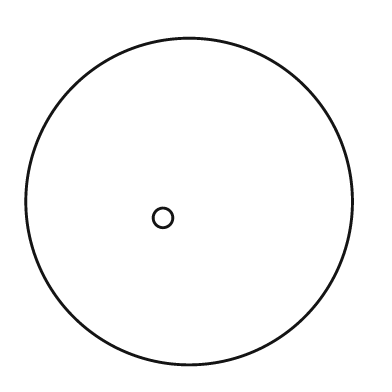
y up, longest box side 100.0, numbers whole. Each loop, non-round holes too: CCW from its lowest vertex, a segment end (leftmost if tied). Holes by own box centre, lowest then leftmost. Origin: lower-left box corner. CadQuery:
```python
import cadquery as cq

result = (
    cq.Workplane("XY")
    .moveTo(50.0, 50.0)
    .circle(50.0)
    .moveTo(42.0, 45.0)
    .circle(3.0)
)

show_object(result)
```